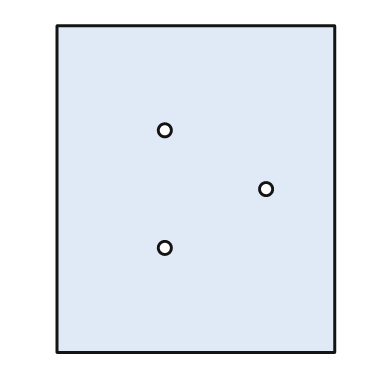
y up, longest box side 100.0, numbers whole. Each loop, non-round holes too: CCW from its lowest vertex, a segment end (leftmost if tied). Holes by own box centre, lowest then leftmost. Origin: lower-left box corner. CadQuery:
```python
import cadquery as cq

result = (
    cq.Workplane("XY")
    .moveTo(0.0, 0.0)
    .lineTo(85.0, 0.0)
    .lineTo(85.0, 100.0)
    .lineTo(0.0, 100.0)
    .close()
    .moveTo(33.0, 32.0)
    .circle(2.0)
    .moveTo(64.0, 50.0)
    .circle(2.0)
    .moveTo(33.0, 68.0)
    .circle(2.0)
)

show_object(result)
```